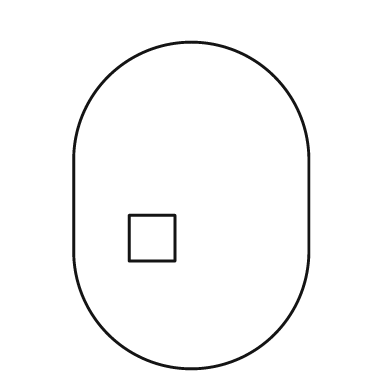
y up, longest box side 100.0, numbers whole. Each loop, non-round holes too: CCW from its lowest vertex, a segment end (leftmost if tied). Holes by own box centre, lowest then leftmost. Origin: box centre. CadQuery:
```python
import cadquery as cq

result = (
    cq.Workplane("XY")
    .moveTo(-36.0, -14.0)
    .threePointArc((0.0, -50.0), (36.0, -14.0))
    .lineTo(36.0, 14.0)
    .threePointArc((0.0, 50.0), (-36.0, 14.0))
    .close()
    .moveTo(-19.0, -17.0)
    .lineTo(-5.0, -17.0)
    .lineTo(-5.0, -3.0)
    .lineTo(-19.0, -3.0)
    .close()
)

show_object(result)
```